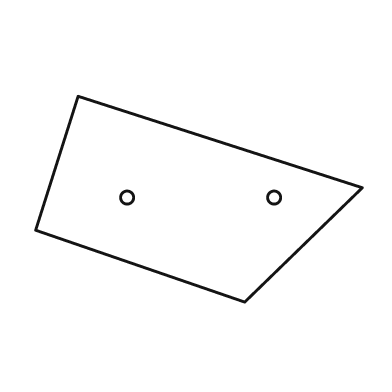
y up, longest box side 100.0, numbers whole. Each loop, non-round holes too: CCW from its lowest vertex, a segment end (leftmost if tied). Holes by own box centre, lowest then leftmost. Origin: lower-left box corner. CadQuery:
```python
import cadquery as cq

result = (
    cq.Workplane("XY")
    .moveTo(64.0, 0.0)
    .lineTo(100.0, 35.0)
    .lineTo(13.0, 63.0)
    .lineTo(0.0, 22.0)
    .close()
    .moveTo(28.0, 32.0)
    .circle(2.0)
    .moveTo(73.0, 32.0)
    .circle(2.0)
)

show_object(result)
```